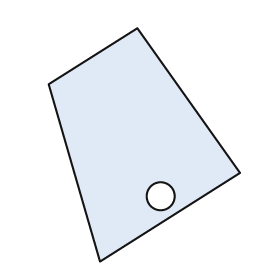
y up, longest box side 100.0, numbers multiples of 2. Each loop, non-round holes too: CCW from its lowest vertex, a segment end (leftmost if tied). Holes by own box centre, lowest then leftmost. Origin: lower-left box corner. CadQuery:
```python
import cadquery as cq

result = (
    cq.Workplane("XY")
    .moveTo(22.0, 0.0)
    .lineTo(82.0, 38.0)
    .lineTo(38.0, 100.0)
    .lineTo(0.0, 76.0)
    .close()
    .moveTo(48.0, 28.0)
    .circle(6.0)
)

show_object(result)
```